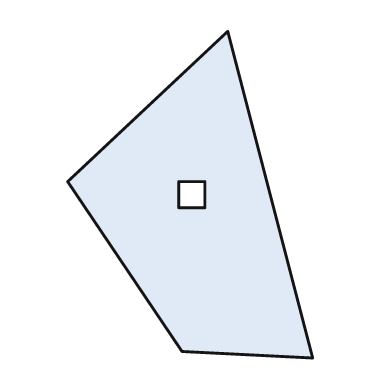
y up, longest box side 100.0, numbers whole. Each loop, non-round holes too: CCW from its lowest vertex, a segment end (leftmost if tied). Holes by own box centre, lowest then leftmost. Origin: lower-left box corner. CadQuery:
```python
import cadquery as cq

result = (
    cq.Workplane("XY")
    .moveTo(75.0, 0.0)
    .lineTo(49.0, 100.0)
    .lineTo(0.0, 54.0)
    .lineTo(35.0, 2.0)
    .close()
    .moveTo(34.0, 46.0)
    .lineTo(42.0, 46.0)
    .lineTo(42.0, 54.0)
    .lineTo(34.0, 54.0)
    .close()
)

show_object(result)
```